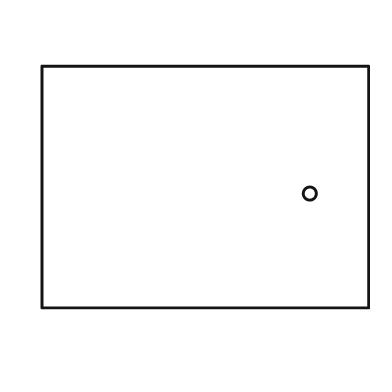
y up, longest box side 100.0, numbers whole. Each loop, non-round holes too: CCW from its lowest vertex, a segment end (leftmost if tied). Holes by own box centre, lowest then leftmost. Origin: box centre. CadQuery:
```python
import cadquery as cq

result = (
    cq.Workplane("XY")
    .moveTo(-50.0, -37.0)
    .lineTo(50.0, -37.0)
    .lineTo(50.0, 37.0)
    .lineTo(-50.0, 37.0)
    .close()
    .moveTo(32.0, -2.0)
    .circle(2.0)
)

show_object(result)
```